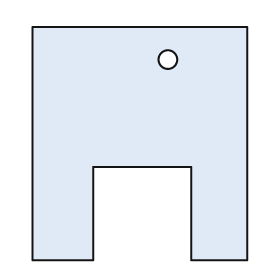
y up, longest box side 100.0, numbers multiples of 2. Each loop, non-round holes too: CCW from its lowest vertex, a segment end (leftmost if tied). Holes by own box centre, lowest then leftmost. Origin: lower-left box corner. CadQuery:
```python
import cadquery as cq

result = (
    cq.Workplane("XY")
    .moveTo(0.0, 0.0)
    .lineTo(26.0, 0.0)
    .lineTo(26.0, 40.0)
    .lineTo(68.0, 40.0)
    .lineTo(68.0, 0.0)
    .lineTo(92.0, 0.0)
    .lineTo(92.0, 100.0)
    .lineTo(0.0, 100.0)
    .close()
    .moveTo(58.0, 86.0)
    .circle(4.0)
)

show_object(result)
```